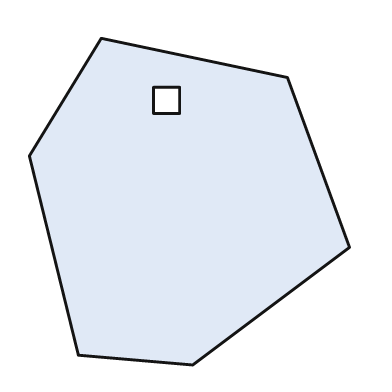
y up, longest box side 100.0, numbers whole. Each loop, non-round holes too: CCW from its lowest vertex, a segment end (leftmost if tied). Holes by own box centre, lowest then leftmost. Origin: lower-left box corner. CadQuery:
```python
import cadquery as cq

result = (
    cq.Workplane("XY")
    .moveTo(50.0, 0.0)
    .lineTo(98.0, 36.0)
    .lineTo(79.0, 88.0)
    .lineTo(22.0, 100.0)
    .lineTo(0.0, 64.0)
    .lineTo(15.0, 3.0)
    .close()
    .moveTo(38.0, 77.0)
    .lineTo(46.0, 77.0)
    .lineTo(46.0, 85.0)
    .lineTo(38.0, 85.0)
    .close()
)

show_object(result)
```